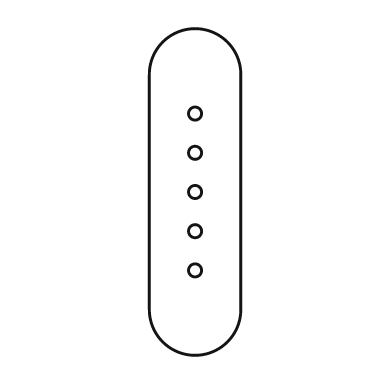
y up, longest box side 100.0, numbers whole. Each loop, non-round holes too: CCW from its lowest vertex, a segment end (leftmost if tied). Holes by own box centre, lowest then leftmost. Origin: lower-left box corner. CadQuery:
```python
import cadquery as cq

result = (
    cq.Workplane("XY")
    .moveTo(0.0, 14.0)
    .threePointArc((14.0, 0.0), (28.0, 14.0))
    .lineTo(28.0, 86.0)
    .threePointArc((14.0, 100.0), (0.0, 86.0))
    .close()
    .moveTo(14.0, 26.0)
    .circle(2.0)
    .moveTo(14.0, 38.0)
    .circle(2.0)
    .moveTo(14.0, 50.0)
    .circle(2.0)
    .moveTo(14.0, 62.0)
    .circle(2.0)
    .moveTo(14.0, 74.0)
    .circle(2.0)
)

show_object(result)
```